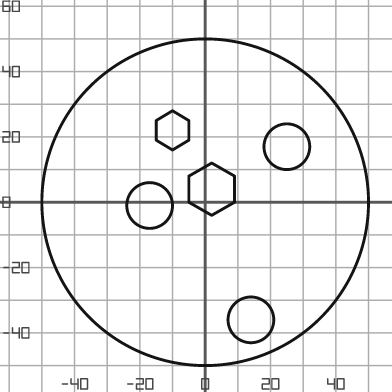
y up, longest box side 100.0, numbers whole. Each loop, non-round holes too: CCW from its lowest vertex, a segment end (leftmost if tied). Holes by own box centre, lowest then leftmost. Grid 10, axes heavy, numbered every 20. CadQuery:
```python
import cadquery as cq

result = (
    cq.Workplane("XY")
    .moveTo(0.0, 0.0)
    .circle(50.0)
    .moveTo(14.0, -36.0)
    .circle(7.0)
    .moveTo(-17.0, -1.0)
    .circle(7.0)
    .moveTo(2.0, -4.0)
    .lineTo(9.0, 0.0)
    .lineTo(9.0, 8.0)
    .lineTo(2.0, 12.0)
    .lineTo(-5.0, 8.0)
    .lineTo(-5.0, 0.0)
    .close()
    .moveTo(25.0, 17.0)
    .circle(7.0)
    .moveTo(-10.0, 16.0)
    .lineTo(-5.0, 19.0)
    .lineTo(-5.0, 25.0)
    .lineTo(-10.0, 28.0)
    .lineTo(-15.0, 25.0)
    .lineTo(-15.0, 19.0)
    .close()
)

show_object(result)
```